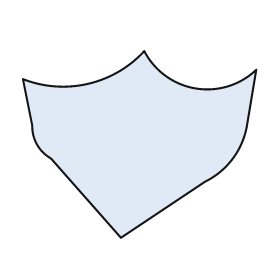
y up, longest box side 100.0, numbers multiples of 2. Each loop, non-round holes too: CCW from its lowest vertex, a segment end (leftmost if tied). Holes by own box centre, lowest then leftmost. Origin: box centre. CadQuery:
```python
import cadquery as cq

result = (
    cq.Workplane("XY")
    .moveTo(-8.0, -40.0)
    .lineTo(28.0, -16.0)
    .threePointArc((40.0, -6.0), (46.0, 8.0))
    .lineTo(50.0, 32.0)
    .threePointArc((24.0, 24.0), (2.0, 40.0))
    .threePointArc((-22.0, 26.0), (-50.0, 28.0))
    .lineTo(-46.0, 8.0)
    .threePointArc((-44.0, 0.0), (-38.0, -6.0))
    .close()
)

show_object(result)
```